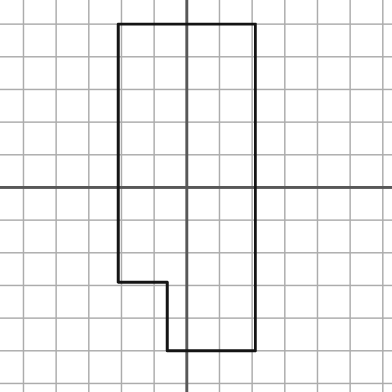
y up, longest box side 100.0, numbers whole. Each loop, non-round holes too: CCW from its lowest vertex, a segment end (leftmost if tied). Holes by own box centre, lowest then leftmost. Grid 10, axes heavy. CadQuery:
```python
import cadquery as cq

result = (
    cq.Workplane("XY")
    .moveTo(-6.0, -50.0)
    .lineTo(21.0, -50.0)
    .lineTo(21.0, 50.0)
    .lineTo(-21.0, 50.0)
    .lineTo(-21.0, -29.0)
    .lineTo(-6.0, -29.0)
    .close()
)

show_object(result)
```